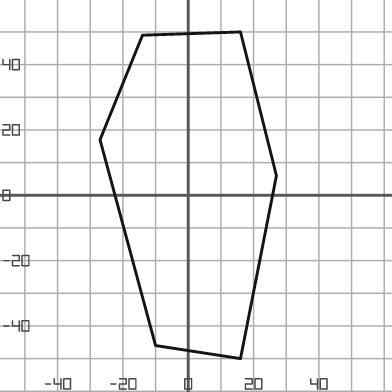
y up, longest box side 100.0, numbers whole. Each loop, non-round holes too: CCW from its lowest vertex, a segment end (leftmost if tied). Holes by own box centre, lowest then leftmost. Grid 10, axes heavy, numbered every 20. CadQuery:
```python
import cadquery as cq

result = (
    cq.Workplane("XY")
    .moveTo(16.0, -50.0)
    .lineTo(27.0, 6.0)
    .lineTo(16.0, 50.0)
    .lineTo(-14.0, 49.0)
    .lineTo(-27.0, 17.0)
    .lineTo(-10.0, -46.0)
    .close()
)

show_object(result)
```